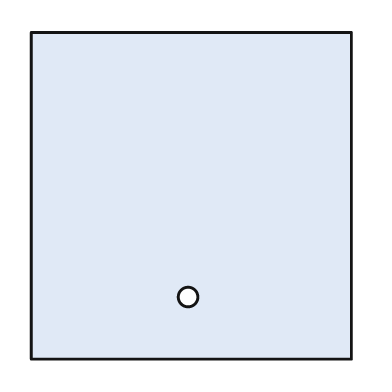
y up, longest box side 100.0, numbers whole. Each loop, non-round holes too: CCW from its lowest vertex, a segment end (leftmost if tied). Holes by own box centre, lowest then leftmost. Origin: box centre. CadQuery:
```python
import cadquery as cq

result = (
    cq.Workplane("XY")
    .moveTo(-49.0, -50.0)
    .lineTo(49.0, -50.0)
    .lineTo(49.0, 50.0)
    .lineTo(-49.0, 50.0)
    .close()
    .moveTo(-1.0, -31.0)
    .circle(3.0)
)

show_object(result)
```